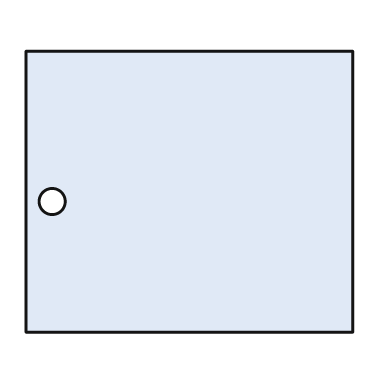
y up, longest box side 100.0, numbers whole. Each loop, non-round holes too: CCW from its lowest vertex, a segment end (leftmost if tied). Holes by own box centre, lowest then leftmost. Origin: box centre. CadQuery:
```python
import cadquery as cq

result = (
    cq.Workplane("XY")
    .moveTo(-50.0, -43.0)
    .lineTo(50.0, -43.0)
    .lineTo(50.0, 43.0)
    .lineTo(-50.0, 43.0)
    .close()
    .moveTo(-42.0, -3.0)
    .circle(4.0)
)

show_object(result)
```